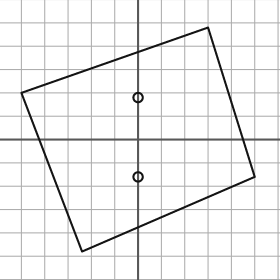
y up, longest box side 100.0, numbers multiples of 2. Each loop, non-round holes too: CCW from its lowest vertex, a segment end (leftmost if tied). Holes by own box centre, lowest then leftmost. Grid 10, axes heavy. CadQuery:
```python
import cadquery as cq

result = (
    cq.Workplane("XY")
    .moveTo(-24.0, -48.0)
    .lineTo(50.0, -16.0)
    .lineTo(30.0, 48.0)
    .lineTo(-50.0, 20.0)
    .close()
    .moveTo(0.0, -16.0)
    .circle(2.0)
    .moveTo(0.0, 18.0)
    .circle(2.0)
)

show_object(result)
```